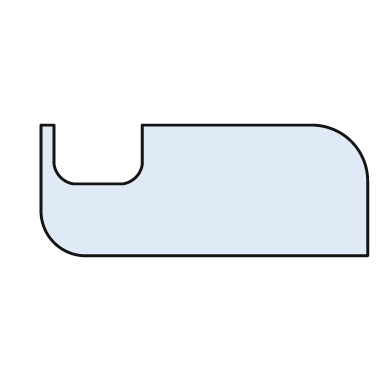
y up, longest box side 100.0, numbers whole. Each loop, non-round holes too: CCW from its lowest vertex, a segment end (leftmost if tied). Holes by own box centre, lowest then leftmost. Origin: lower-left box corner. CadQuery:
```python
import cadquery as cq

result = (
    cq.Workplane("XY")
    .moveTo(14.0, 0.0)
    .lineTo(100.0, 0.0)
    .lineTo(100.0, 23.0)
    .threePointArc((95.0, 35.0), (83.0, 40.0))
    .lineTo(31.0, 40.0)
    .lineTo(31.0, 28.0)
    .threePointArc((29.0, 24.0), (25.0, 22.0))
    .lineTo(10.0, 22.0)
    .threePointArc((6.0, 24.0), (4.0, 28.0))
    .lineTo(4.0, 40.0)
    .lineTo(0.0, 40.0)
    .lineTo(0.0, 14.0)
    .threePointArc((4.0, 4.0), (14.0, 0.0))
    .close()
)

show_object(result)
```